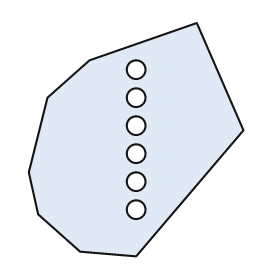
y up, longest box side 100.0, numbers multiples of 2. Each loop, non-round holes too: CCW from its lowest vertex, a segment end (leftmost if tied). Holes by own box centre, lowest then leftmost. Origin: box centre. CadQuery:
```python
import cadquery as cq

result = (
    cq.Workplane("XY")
    .moveTo(0.0, -50.0)
    .lineTo(46.0, 4.0)
    .lineTo(26.0, 50.0)
    .lineTo(-20.0, 34.0)
    .lineTo(-38.0, 18.0)
    .lineTo(-46.0, -14.0)
    .lineTo(-42.0, -32.0)
    .lineTo(-24.0, -48.0)
    .close()
    .moveTo(0.0, -30.0)
    .circle(4.0)
    .moveTo(0.0, -18.0)
    .circle(4.0)
    .moveTo(0.0, -6.0)
    .circle(4.0)
    .moveTo(0.0, 6.0)
    .circle(4.0)
    .moveTo(0.0, 18.0)
    .circle(4.0)
    .moveTo(0.0, 30.0)
    .circle(4.0)
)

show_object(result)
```